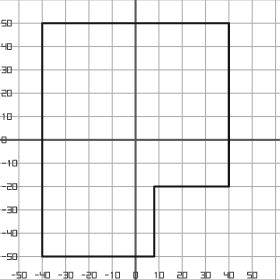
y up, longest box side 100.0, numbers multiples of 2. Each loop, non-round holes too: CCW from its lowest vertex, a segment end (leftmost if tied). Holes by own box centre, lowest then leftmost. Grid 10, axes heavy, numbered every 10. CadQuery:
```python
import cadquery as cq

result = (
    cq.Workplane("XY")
    .moveTo(-40.0, -50.0)
    .lineTo(8.0, -50.0)
    .lineTo(8.0, -20.0)
    .lineTo(40.0, -20.0)
    .lineTo(40.0, 50.0)
    .lineTo(-40.0, 50.0)
    .close()
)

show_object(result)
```